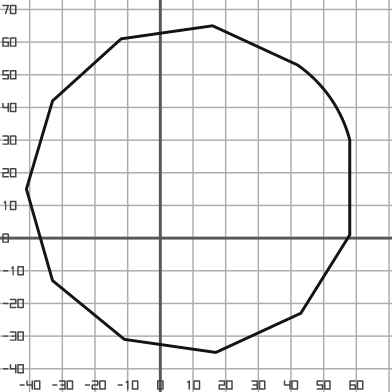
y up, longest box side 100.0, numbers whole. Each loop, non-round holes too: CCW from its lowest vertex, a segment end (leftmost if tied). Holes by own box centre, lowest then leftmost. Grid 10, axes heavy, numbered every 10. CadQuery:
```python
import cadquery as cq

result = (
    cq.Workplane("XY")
    .moveTo(17.0, -35.0)
    .lineTo(43.0, -23.0)
    .lineTo(58.0, 1.0)
    .lineTo(58.0, 30.0)
    .threePointArc((52.0, 43.0), (42.0, 53.0))
    .lineTo(16.0, 65.0)
    .lineTo(-12.0, 61.0)
    .lineTo(-33.0, 42.0)
    .lineTo(-41.0, 15.0)
    .lineTo(-33.0, -13.0)
    .lineTo(-11.0, -31.0)
    .close()
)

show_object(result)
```